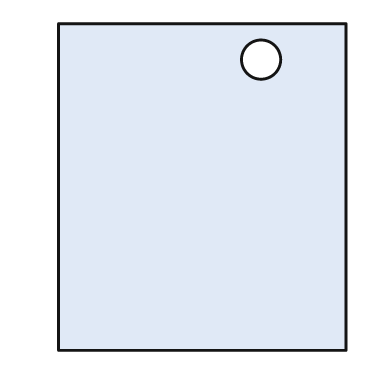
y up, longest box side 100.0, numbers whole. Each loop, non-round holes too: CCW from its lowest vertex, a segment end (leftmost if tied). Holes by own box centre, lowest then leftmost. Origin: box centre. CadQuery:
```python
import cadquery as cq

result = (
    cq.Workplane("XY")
    .moveTo(-44.0, -50.0)
    .lineTo(44.0, -50.0)
    .lineTo(44.0, 50.0)
    .lineTo(-44.0, 50.0)
    .close()
    .moveTo(18.0, 39.0)
    .circle(6.0)
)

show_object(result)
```